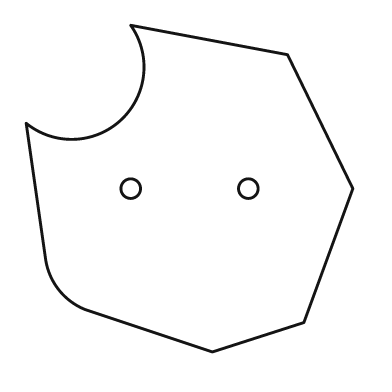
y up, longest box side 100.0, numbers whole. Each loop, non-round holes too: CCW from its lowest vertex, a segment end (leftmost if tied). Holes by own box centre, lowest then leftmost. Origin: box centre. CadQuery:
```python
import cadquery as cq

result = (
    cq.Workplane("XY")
    .moveTo(7.0, -50.0)
    .lineTo(35.0, -41.0)
    .lineTo(50.0, 0.0)
    .lineTo(30.0, 41.0)
    .lineTo(-18.0, 50.0)
    .threePointArc((-21.0, 21.0), (-50.0, 20.0))
    .lineTo(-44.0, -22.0)
    .threePointArc((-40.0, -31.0), (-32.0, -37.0))
    .close()
    .moveTo(-18.0, 0.0)
    .circle(3.0)
    .moveTo(18.0, 0.0)
    .circle(3.0)
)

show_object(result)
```